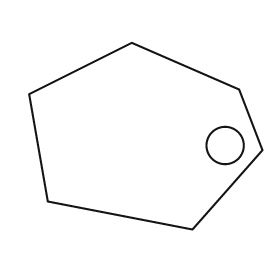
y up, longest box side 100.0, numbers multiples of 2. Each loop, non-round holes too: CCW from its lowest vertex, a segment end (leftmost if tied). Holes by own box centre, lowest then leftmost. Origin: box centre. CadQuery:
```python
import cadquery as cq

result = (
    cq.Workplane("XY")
    .moveTo(20.0, -40.0)
    .lineTo(50.0, -6.0)
    .lineTo(40.0, 20.0)
    .lineTo(-6.0, 40.0)
    .lineTo(-50.0, 18.0)
    .lineTo(-42.0, -28.0)
    .close()
    .moveTo(34.0, -4.0)
    .circle(8.0)
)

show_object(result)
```